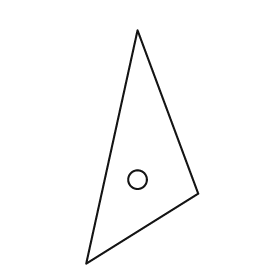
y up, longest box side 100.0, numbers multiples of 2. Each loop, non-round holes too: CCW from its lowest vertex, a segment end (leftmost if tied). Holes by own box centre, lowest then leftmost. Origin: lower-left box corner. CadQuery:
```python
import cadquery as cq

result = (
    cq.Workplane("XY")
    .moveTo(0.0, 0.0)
    .lineTo(48.0, 30.0)
    .lineTo(22.0, 100.0)
    .close()
    .moveTo(22.0, 36.0)
    .circle(4.0)
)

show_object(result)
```